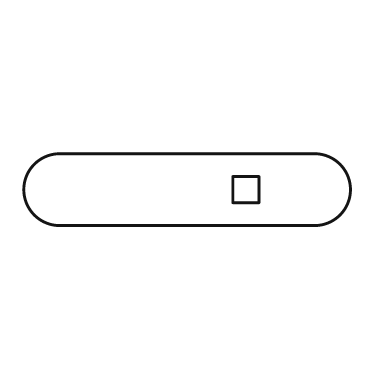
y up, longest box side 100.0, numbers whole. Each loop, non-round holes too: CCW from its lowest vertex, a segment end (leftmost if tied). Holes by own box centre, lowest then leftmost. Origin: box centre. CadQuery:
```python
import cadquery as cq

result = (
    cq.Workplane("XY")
    .moveTo(-39.0, -11.0)
    .lineTo(39.0, -11.0)
    .threePointArc((50.0, 0.0), (39.0, 11.0))
    .lineTo(-39.0, 11.0)
    .threePointArc((-50.0, 0.0), (-39.0, -11.0))
    .close()
    .moveTo(14.0, -4.0)
    .lineTo(22.0, -4.0)
    .lineTo(22.0, 4.0)
    .lineTo(14.0, 4.0)
    .close()
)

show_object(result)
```